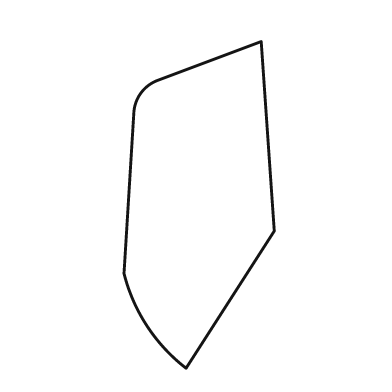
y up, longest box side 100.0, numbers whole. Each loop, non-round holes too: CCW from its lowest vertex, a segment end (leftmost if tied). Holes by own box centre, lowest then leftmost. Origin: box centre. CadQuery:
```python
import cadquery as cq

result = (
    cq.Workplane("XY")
    .moveTo(-4.0, -50.0)
    .lineTo(23.0, -8.0)
    .lineTo(19.0, 50.0)
    .lineTo(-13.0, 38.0)
    .threePointArc((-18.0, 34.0), (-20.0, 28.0))
    .lineTo(-23.0, -21.0)
    .threePointArc((-16.0, -37.0), (-4.0, -50.0))
    .close()
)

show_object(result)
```